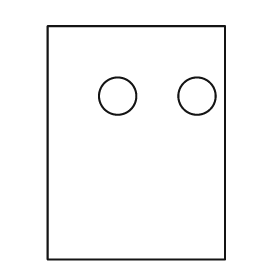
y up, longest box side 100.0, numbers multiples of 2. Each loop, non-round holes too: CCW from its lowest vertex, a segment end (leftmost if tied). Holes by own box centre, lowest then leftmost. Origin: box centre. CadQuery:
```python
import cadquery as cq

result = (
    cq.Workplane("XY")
    .moveTo(-38.0, -50.0)
    .lineTo(38.0, -50.0)
    .lineTo(38.0, 50.0)
    .lineTo(-38.0, 50.0)
    .close()
    .moveTo(-8.0, 20.0)
    .circle(8.0)
    .moveTo(26.0, 20.0)
    .circle(8.0)
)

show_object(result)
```